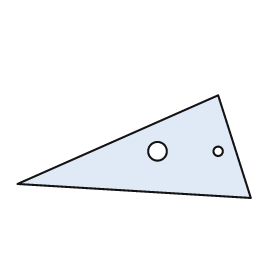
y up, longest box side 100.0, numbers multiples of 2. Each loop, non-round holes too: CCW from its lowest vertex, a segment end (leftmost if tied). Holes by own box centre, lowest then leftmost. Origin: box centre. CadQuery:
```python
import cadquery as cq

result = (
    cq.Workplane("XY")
    .moveTo(50.0, -22.0)
    .lineTo(36.0, 22.0)
    .lineTo(-50.0, -16.0)
    .close()
    .moveTo(10.0, -2.0)
    .circle(4.0)
    .moveTo(36.0, -2.0)
    .circle(2.0)
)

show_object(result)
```